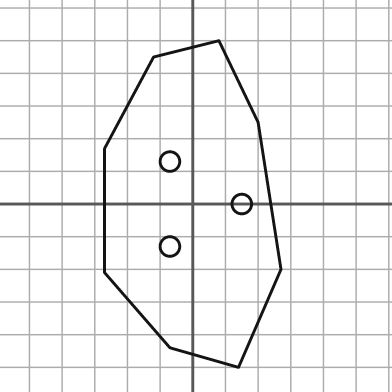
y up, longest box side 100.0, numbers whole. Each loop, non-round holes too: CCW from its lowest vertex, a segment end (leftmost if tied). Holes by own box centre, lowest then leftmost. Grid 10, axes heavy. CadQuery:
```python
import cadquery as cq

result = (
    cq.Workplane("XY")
    .moveTo(14.0, -50.0)
    .lineTo(27.0, -20.0)
    .lineTo(20.0, 25.0)
    .lineTo(8.0, 50.0)
    .lineTo(-12.0, 45.0)
    .lineTo(-27.0, 17.0)
    .lineTo(-27.0, -21.0)
    .lineTo(-7.0, -44.0)
    .close()
    .moveTo(-7.0, -13.0)
    .circle(3.0)
    .moveTo(15.0, 0.0)
    .circle(3.0)
    .moveTo(-7.0, 13.0)
    .circle(3.0)
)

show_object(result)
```